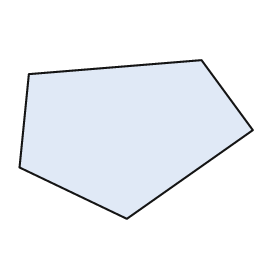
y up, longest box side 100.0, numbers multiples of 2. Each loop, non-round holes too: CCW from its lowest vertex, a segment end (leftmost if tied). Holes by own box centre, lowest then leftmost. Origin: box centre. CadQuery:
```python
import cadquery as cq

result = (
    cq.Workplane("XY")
    .moveTo(-4.0, -34.0)
    .lineTo(50.0, 4.0)
    .lineTo(28.0, 34.0)
    .lineTo(-46.0, 28.0)
    .lineTo(-50.0, -12.0)
    .close()
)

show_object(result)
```